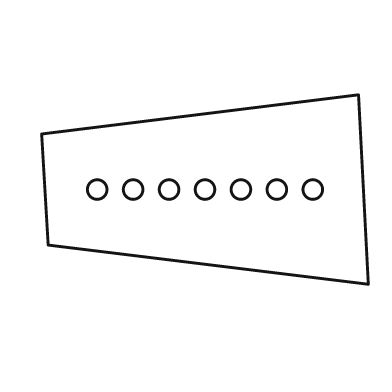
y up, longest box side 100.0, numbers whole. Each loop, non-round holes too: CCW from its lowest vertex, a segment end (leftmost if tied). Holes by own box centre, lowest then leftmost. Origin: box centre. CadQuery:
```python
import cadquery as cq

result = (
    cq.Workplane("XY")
    .moveTo(50.0, -29.0)
    .lineTo(47.0, 29.0)
    .lineTo(-50.0, 17.0)
    .lineTo(-48.0, -17.0)
    .close()
    .moveTo(-33.0, 0.0)
    .circle(3.0)
    .moveTo(-22.0, 0.0)
    .circle(3.0)
    .moveTo(-11.0, 0.0)
    .circle(3.0)
    .moveTo(0.0, 0.0)
    .circle(3.0)
    .moveTo(11.0, 0.0)
    .circle(3.0)
    .moveTo(22.0, 0.0)
    .circle(3.0)
    .moveTo(33.0, 0.0)
    .circle(3.0)
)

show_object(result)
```